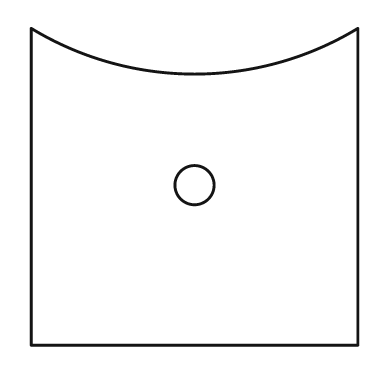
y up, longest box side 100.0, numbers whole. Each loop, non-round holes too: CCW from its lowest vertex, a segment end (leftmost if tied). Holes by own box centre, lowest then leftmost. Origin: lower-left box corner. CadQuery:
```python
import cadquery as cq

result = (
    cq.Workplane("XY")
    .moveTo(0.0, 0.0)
    .lineTo(100.0, 0.0)
    .lineTo(100.0, 97.0)
    .threePointArc((50.0, 83.0), (0.0, 97.0))
    .close()
    .moveTo(50.0, 49.0)
    .circle(6.0)
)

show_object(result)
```